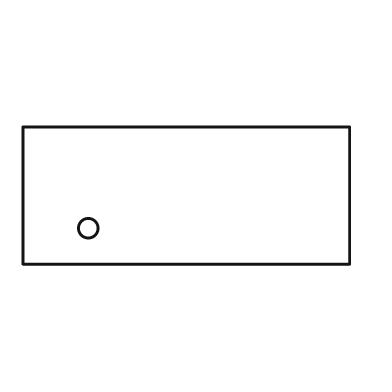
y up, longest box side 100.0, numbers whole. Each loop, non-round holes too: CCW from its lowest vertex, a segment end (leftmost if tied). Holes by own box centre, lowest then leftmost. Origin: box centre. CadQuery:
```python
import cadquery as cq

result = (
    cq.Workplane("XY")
    .moveTo(-50.0, -21.0)
    .lineTo(50.0, -21.0)
    .lineTo(50.0, 21.0)
    .lineTo(-50.0, 21.0)
    .close()
    .moveTo(-30.0, -10.0)
    .circle(3.0)
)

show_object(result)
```